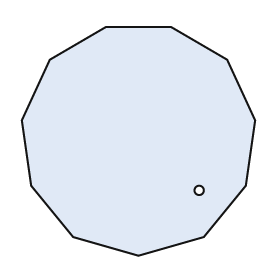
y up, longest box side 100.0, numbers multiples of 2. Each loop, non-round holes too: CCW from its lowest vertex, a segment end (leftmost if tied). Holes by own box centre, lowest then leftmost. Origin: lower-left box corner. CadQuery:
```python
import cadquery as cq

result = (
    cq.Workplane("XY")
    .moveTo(50.0, 0.0)
    .lineTo(78.0, 8.0)
    .lineTo(96.0, 30.0)
    .lineTo(100.0, 58.0)
    .lineTo(88.0, 84.0)
    .lineTo(64.0, 98.0)
    .lineTo(36.0, 98.0)
    .lineTo(12.0, 84.0)
    .lineTo(0.0, 58.0)
    .lineTo(4.0, 30.0)
    .lineTo(22.0, 8.0)
    .close()
    .moveTo(76.0, 28.0)
    .circle(2.0)
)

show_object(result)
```